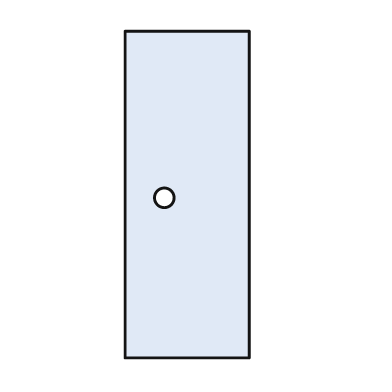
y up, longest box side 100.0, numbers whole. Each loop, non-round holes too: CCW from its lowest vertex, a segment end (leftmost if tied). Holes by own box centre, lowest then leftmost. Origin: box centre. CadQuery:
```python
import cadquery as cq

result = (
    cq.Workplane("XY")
    .moveTo(-19.0, -50.0)
    .lineTo(19.0, -50.0)
    .lineTo(19.0, 50.0)
    .lineTo(-19.0, 50.0)
    .close()
    .moveTo(-7.0, -1.0)
    .circle(3.0)
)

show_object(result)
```